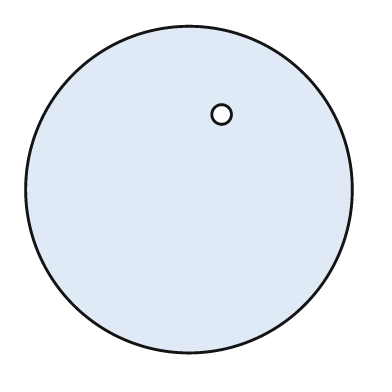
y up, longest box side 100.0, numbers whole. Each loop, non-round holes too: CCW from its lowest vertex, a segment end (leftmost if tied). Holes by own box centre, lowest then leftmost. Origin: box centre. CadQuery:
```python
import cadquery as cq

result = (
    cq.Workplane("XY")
    .moveTo(0.0, 0.0)
    .circle(50.0)
    .moveTo(10.0, 23.0)
    .circle(3.0)
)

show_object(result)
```